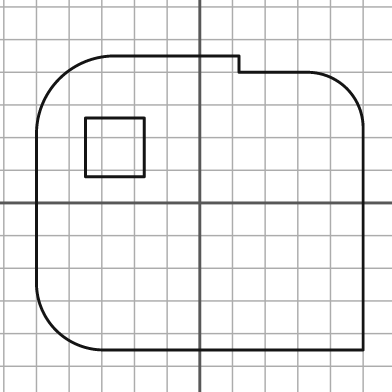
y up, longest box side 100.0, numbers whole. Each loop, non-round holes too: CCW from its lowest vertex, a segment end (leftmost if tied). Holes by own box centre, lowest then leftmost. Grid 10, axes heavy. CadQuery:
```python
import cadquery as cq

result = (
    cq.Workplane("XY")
    .moveTo(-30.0, -45.0)
    .lineTo(50.0, -45.0)
    .lineTo(50.0, 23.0)
    .threePointArc((45.0, 35.0), (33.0, 40.0))
    .lineTo(12.0, 40.0)
    .lineTo(12.0, 45.0)
    .lineTo(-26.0, 45.0)
    .threePointArc((-43.0, 38.0), (-50.0, 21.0))
    .lineTo(-50.0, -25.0)
    .threePointArc((-44.0, -39.0), (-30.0, -45.0))
    .close()
    .moveTo(-35.0, 8.0)
    .lineTo(-17.0, 8.0)
    .lineTo(-17.0, 26.0)
    .lineTo(-35.0, 26.0)
    .close()
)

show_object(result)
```